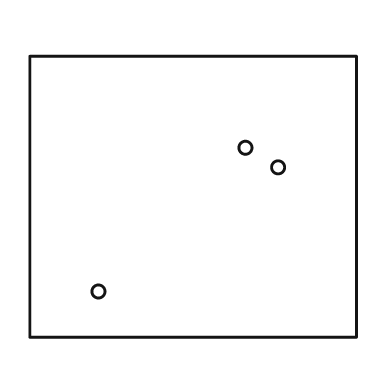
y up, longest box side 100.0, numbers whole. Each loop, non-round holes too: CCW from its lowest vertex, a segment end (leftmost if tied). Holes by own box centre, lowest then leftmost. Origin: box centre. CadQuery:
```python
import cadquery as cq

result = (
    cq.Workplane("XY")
    .moveTo(-50.0, -43.0)
    .lineTo(50.0, -43.0)
    .lineTo(50.0, 43.0)
    .lineTo(-50.0, 43.0)
    .close()
    .moveTo(-29.0, -29.0)
    .circle(2.0)
    .moveTo(26.0, 9.0)
    .circle(2.0)
    .moveTo(16.0, 15.0)
    .circle(2.0)
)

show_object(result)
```